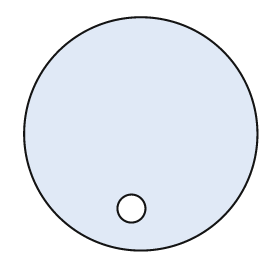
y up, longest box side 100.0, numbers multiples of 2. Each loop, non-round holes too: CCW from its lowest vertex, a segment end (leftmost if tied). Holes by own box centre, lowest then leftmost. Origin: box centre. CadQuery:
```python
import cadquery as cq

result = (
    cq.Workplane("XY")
    .moveTo(0.0, 0.0)
    .circle(50.0)
    .moveTo(-4.0, -32.0)
    .circle(6.0)
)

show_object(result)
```